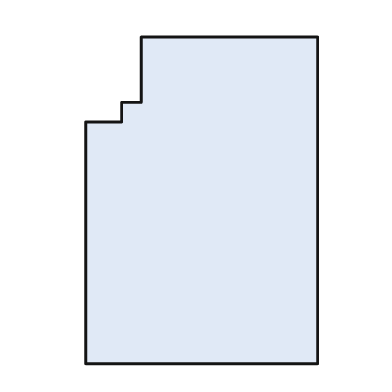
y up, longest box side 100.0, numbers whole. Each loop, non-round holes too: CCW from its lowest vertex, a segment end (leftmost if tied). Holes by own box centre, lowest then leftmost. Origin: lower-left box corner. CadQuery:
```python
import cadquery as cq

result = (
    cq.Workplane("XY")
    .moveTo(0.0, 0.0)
    .lineTo(71.0, 0.0)
    .lineTo(71.0, 100.0)
    .lineTo(17.0, 100.0)
    .lineTo(17.0, 80.0)
    .lineTo(11.0, 80.0)
    .lineTo(11.0, 74.0)
    .lineTo(0.0, 74.0)
    .close()
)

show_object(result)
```